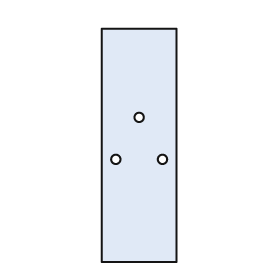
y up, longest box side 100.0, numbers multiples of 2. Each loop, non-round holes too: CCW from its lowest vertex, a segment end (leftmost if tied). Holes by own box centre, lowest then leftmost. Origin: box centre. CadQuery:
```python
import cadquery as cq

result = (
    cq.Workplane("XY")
    .moveTo(-16.0, -50.0)
    .lineTo(16.0, -50.0)
    .lineTo(16.0, 50.0)
    .lineTo(-16.0, 50.0)
    .close()
    .moveTo(-10.0, -6.0)
    .circle(2.0)
    .moveTo(10.0, -6.0)
    .circle(2.0)
    .moveTo(0.0, 12.0)
    .circle(2.0)
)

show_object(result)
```